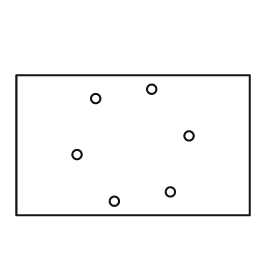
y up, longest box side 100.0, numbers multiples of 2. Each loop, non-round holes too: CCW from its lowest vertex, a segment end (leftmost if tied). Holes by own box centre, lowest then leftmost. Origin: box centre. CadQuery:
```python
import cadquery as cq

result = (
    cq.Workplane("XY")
    .moveTo(-50.0, -30.0)
    .lineTo(50.0, -30.0)
    .lineTo(50.0, 30.0)
    .lineTo(-50.0, 30.0)
    .close()
    .moveTo(-8.0, -24.0)
    .circle(2.0)
    .moveTo(16.0, -20.0)
    .circle(2.0)
    .moveTo(-24.0, -4.0)
    .circle(2.0)
    .moveTo(24.0, 4.0)
    .circle(2.0)
    .moveTo(-16.0, 20.0)
    .circle(2.0)
    .moveTo(8.0, 24.0)
    .circle(2.0)
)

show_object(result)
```